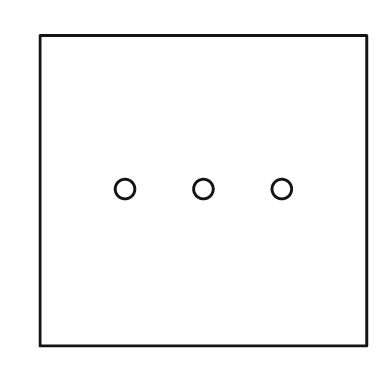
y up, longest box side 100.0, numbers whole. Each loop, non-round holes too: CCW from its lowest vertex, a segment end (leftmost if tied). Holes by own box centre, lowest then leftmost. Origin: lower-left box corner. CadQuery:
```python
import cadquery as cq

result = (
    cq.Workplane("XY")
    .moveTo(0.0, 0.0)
    .lineTo(100.0, 0.0)
    .lineTo(100.0, 95.0)
    .lineTo(0.0, 95.0)
    .close()
    .moveTo(26.0, 48.0)
    .circle(3.0)
    .moveTo(50.0, 48.0)
    .circle(3.0)
    .moveTo(74.0, 48.0)
    .circle(3.0)
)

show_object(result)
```